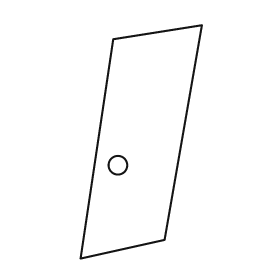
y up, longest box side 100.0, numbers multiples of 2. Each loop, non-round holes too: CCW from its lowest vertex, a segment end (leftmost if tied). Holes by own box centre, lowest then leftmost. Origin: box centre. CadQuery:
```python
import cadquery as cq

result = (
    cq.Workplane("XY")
    .moveTo(-26.0, -50.0)
    .lineTo(10.0, -42.0)
    .lineTo(26.0, 50.0)
    .lineTo(-12.0, 44.0)
    .close()
    .moveTo(-10.0, -10.0)
    .circle(4.0)
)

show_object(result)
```